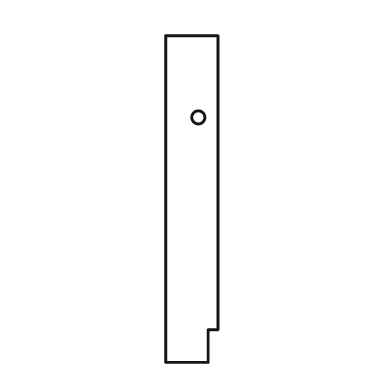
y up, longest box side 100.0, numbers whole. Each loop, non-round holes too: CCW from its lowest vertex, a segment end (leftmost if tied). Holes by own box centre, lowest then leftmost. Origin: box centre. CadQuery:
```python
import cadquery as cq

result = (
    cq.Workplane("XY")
    .moveTo(-8.0, -50.0)
    .lineTo(5.0, -50.0)
    .lineTo(5.0, -40.0)
    .lineTo(8.0, -40.0)
    .lineTo(8.0, 50.0)
    .lineTo(-8.0, 50.0)
    .close()
    .moveTo(2.0, 25.0)
    .circle(2.0)
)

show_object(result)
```